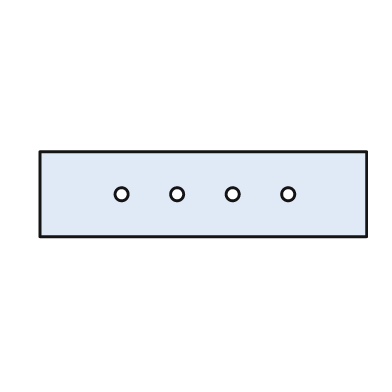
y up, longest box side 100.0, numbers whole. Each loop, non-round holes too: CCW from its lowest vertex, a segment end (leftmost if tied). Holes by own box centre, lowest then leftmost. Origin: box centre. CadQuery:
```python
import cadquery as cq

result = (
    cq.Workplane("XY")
    .moveTo(-50.0, -13.0)
    .lineTo(50.0, -13.0)
    .lineTo(50.0, 13.0)
    .lineTo(-50.0, 13.0)
    .close()
    .moveTo(-25.0, 0.0)
    .circle(2.0)
    .moveTo(-8.0, 0.0)
    .circle(2.0)
    .moveTo(9.0, 0.0)
    .circle(2.0)
    .moveTo(26.0, 0.0)
    .circle(2.0)
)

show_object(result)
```